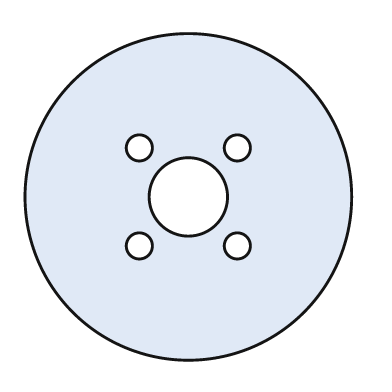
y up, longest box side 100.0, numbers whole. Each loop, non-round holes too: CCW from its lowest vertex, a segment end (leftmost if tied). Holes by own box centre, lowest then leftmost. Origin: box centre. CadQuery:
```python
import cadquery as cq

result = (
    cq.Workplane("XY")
    .moveTo(0.0, 0.0)
    .circle(50.0)
    .moveTo(-15.0, -15.0)
    .circle(4.0)
    .moveTo(15.0, -15.0)
    .circle(4.0)
    .moveTo(0.0, 0.0)
    .circle(12.0)
    .moveTo(-15.0, 15.0)
    .circle(4.0)
    .moveTo(15.0, 15.0)
    .circle(4.0)
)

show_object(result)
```